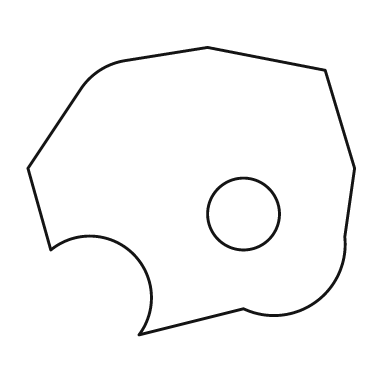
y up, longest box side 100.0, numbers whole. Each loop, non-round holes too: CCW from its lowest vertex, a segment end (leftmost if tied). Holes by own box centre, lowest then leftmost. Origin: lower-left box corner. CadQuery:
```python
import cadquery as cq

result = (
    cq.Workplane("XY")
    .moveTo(34.0, 0.0)
    .lineTo(66.0, 8.0)
    .threePointArc((88.0, 10.0), (97.0, 30.0))
    .lineTo(100.0, 51.0)
    .lineTo(91.0, 81.0)
    .lineTo(55.0, 88.0)
    .lineTo(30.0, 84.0)
    .threePointArc((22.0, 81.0), (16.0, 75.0))
    .lineTo(0.0, 51.0)
    .lineTo(7.0, 26.0)
    .threePointArc((32.0, 25.0), (34.0, 0.0))
    .close()
    .moveTo(66.0, 37.0)
    .circle(11.0)
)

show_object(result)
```